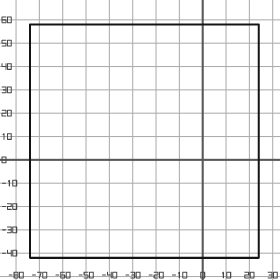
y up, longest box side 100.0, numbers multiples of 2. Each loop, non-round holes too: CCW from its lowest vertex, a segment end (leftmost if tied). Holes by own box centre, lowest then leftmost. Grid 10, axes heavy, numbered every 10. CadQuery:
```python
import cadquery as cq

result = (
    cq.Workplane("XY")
    .moveTo(-74.0, -42.0)
    .lineTo(24.0, -42.0)
    .lineTo(24.0, 58.0)
    .lineTo(-74.0, 58.0)
    .close()
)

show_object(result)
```